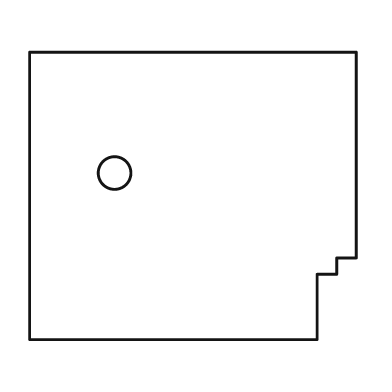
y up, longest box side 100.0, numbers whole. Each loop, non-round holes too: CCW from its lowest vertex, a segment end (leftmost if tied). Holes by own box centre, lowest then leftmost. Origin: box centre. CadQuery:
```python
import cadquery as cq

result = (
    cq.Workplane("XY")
    .moveTo(-50.0, -44.0)
    .lineTo(38.0, -44.0)
    .lineTo(38.0, -24.0)
    .lineTo(44.0, -24.0)
    .lineTo(44.0, -19.0)
    .lineTo(50.0, -19.0)
    .lineTo(50.0, 44.0)
    .lineTo(-50.0, 44.0)
    .close()
    .moveTo(-24.0, 7.0)
    .circle(5.0)
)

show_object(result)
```